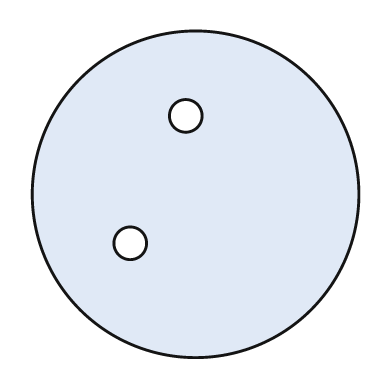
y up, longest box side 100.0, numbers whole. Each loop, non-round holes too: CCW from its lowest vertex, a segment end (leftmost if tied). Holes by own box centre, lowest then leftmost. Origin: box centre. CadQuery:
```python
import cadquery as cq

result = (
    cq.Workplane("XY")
    .moveTo(0.0, 0.0)
    .circle(50.0)
    .moveTo(-20.0, -15.0)
    .circle(5.0)
    .moveTo(-3.0, 24.0)
    .circle(5.0)
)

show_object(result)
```